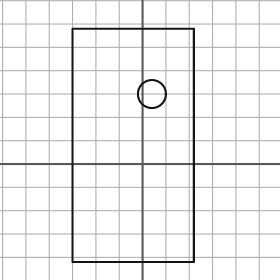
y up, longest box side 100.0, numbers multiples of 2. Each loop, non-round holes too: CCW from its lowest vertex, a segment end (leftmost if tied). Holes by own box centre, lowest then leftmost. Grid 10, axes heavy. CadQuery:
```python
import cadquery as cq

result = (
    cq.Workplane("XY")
    .moveTo(-30.0, -42.0)
    .lineTo(22.0, -42.0)
    .lineTo(22.0, 58.0)
    .lineTo(-30.0, 58.0)
    .close()
    .moveTo(4.0, 30.0)
    .circle(6.0)
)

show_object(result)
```